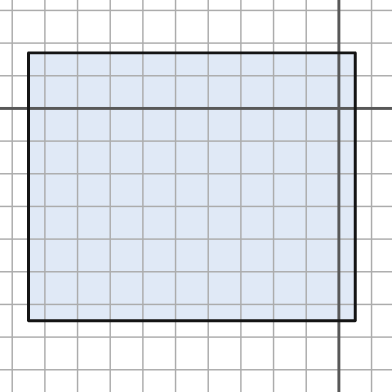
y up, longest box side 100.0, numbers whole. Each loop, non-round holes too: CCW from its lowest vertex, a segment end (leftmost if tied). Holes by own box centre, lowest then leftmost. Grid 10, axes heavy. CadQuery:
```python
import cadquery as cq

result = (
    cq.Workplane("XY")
    .moveTo(-95.0, -65.0)
    .lineTo(5.0, -65.0)
    .lineTo(5.0, 17.0)
    .lineTo(-95.0, 17.0)
    .close()
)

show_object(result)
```